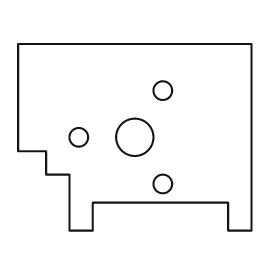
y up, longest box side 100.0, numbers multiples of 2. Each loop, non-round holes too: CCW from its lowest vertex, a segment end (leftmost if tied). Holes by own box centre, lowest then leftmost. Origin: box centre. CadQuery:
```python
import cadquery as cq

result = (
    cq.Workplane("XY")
    .moveTo(-28.0, -40.0)
    .lineTo(-18.0, -40.0)
    .lineTo(-18.0, -28.0)
    .lineTo(40.0, -28.0)
    .lineTo(40.0, -40.0)
    .lineTo(50.0, -40.0)
    .lineTo(50.0, 40.0)
    .lineTo(-50.0, 40.0)
    .lineTo(-50.0, -6.0)
    .lineTo(-38.0, -6.0)
    .lineTo(-38.0, -16.0)
    .lineTo(-28.0, -16.0)
    .close()
    .moveTo(12.0, -20.0)
    .circle(4.0)
    .moveTo(-24.0, 0.0)
    .circle(4.0)
    .moveTo(0.0, 0.0)
    .circle(8.0)
    .moveTo(12.0, 20.0)
    .circle(4.0)
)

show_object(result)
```